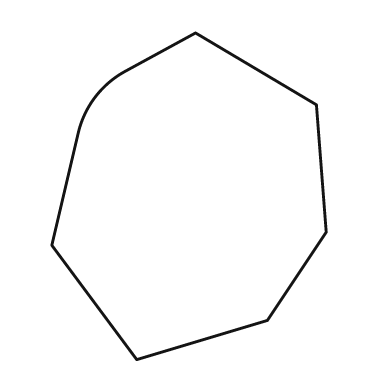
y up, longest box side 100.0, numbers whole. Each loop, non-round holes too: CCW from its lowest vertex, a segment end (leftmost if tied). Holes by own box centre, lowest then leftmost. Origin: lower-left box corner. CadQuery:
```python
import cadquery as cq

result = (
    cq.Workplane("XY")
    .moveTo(26.0, 0.0)
    .lineTo(66.0, 12.0)
    .lineTo(84.0, 39.0)
    .lineTo(81.0, 78.0)
    .lineTo(44.0, 100.0)
    .lineTo(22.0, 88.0)
    .threePointArc((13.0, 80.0), (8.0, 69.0))
    .lineTo(0.0, 35.0)
    .close()
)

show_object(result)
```